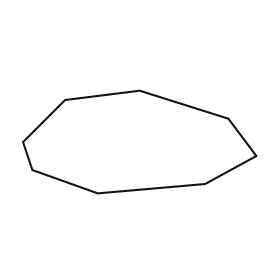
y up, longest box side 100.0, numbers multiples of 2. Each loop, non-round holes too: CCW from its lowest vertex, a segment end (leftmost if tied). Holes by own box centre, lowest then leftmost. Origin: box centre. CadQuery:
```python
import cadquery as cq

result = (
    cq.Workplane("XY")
    .moveTo(-18.0, -22.0)
    .lineTo(28.0, -18.0)
    .lineTo(50.0, -6.0)
    .lineTo(38.0, 10.0)
    .lineTo(0.0, 22.0)
    .lineTo(-32.0, 18.0)
    .lineTo(-50.0, 0.0)
    .lineTo(-46.0, -12.0)
    .close()
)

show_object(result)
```